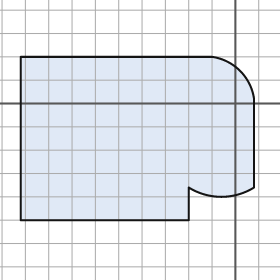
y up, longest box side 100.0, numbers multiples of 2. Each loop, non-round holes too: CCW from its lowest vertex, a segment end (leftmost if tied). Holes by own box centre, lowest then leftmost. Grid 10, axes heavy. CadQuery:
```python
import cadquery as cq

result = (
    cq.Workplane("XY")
    .moveTo(-92.0, -50.0)
    .lineTo(-20.0, -50.0)
    .lineTo(-20.0, -36.0)
    .threePointArc((-6.0, -40.0), (8.0, -36.0))
    .lineTo(8.0, 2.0)
    .threePointArc((2.0, 14.0), (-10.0, 20.0))
    .lineTo(-92.0, 20.0)
    .close()
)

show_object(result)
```